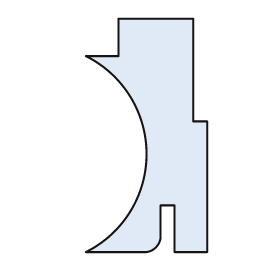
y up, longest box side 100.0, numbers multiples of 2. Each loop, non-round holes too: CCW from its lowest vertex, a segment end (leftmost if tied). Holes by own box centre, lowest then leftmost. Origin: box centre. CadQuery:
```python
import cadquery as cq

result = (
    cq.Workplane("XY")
    .moveTo(-26.0, -50.0)
    .lineTo(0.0, -50.0)
    .threePointArc((4.0, -48.0), (6.0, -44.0))
    .lineTo(6.0, -30.0)
    .lineTo(12.0, -30.0)
    .lineTo(12.0, -50.0)
    .lineTo(26.0, -50.0)
    .lineTo(26.0, 6.0)
    .lineTo(20.0, 6.0)
    .lineTo(20.0, 50.0)
    .lineTo(-12.0, 50.0)
    .lineTo(-12.0, 34.0)
    .lineTo(-26.0, 34.0)
    .threePointArc((0.0, -8.0), (-26.0, -50.0))
    .close()
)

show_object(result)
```